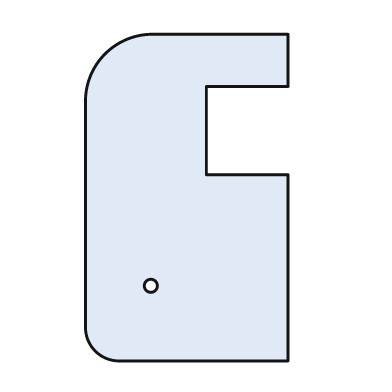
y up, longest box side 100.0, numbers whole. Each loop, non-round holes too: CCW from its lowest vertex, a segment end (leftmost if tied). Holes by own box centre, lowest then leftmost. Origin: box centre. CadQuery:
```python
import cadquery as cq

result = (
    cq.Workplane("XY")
    .moveTo(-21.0, -50.0)
    .lineTo(31.0, -50.0)
    .lineTo(31.0, 7.0)
    .lineTo(6.0, 7.0)
    .lineTo(6.0, 34.0)
    .lineTo(31.0, 34.0)
    .lineTo(31.0, 50.0)
    .lineTo(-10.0, 50.0)
    .threePointArc((-25.0, 44.0), (-31.0, 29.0))
    .lineTo(-31.0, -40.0)
    .threePointArc((-28.0, -47.0), (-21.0, -50.0))
    .close()
    .moveTo(-11.0, -27.0)
    .circle(2.0)
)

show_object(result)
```